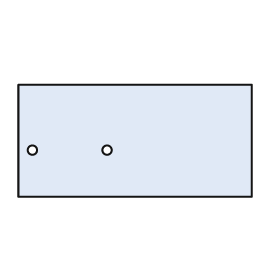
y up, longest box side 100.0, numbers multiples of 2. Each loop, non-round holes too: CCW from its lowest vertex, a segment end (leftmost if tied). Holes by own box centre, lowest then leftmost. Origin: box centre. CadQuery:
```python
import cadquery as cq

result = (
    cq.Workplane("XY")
    .moveTo(-50.0, -24.0)
    .lineTo(50.0, -24.0)
    .lineTo(50.0, 24.0)
    .lineTo(-50.0, 24.0)
    .close()
    .moveTo(-44.0, -4.0)
    .circle(2.0)
    .moveTo(-12.0, -4.0)
    .circle(2.0)
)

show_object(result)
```